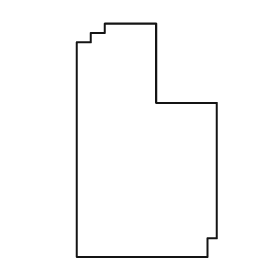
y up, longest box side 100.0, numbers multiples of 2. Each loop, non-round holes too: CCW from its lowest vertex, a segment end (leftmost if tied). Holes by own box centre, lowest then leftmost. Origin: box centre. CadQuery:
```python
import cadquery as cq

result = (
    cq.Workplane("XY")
    .moveTo(-30.0, -50.0)
    .lineTo(26.0, -50.0)
    .lineTo(26.0, -42.0)
    .lineTo(30.0, -42.0)
    .lineTo(30.0, 16.0)
    .lineTo(4.0, 16.0)
    .lineTo(4.0, 50.0)
    .lineTo(-18.0, 50.0)
    .lineTo(-18.0, 46.0)
    .lineTo(-24.0, 46.0)
    .lineTo(-24.0, 42.0)
    .lineTo(-30.0, 42.0)
    .close()
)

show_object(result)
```